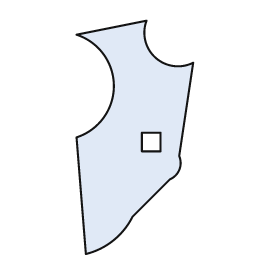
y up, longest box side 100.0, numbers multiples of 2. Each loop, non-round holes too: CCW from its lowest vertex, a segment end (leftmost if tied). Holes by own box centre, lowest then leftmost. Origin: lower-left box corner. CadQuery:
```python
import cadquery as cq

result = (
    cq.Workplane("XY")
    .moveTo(4.0, 0.0)
    .threePointArc((16.0, 6.0), (24.0, 16.0))
    .lineTo(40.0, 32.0)
    .threePointArc((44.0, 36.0), (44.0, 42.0))
    .lineTo(50.0, 82.0)
    .threePointArc((34.0, 84.0), (30.0, 100.0))
    .lineTo(0.0, 94.0)
    .threePointArc((16.0, 72.0), (0.0, 50.0))
    .close()
    .moveTo(28.0, 44.0)
    .lineTo(36.0, 44.0)
    .lineTo(36.0, 52.0)
    .lineTo(28.0, 52.0)
    .close()
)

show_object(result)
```